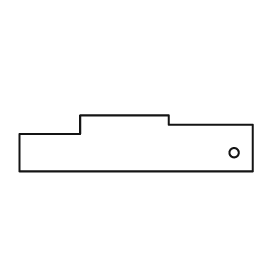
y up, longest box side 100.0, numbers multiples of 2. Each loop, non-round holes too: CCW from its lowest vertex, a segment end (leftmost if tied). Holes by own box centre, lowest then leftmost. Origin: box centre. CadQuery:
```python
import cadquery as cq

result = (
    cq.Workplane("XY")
    .moveTo(-50.0, -12.0)
    .lineTo(50.0, -12.0)
    .lineTo(50.0, 8.0)
    .lineTo(14.0, 8.0)
    .lineTo(14.0, 12.0)
    .lineTo(-24.0, 12.0)
    .lineTo(-24.0, 4.0)
    .lineTo(-50.0, 4.0)
    .close()
    .moveTo(42.0, -4.0)
    .circle(2.0)
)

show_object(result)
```